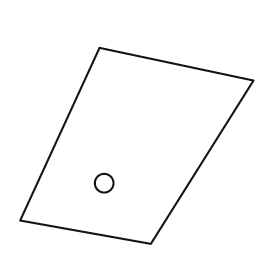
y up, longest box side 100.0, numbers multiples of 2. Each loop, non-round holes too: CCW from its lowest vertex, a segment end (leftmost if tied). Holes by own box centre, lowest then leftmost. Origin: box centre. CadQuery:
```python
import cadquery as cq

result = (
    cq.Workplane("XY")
    .moveTo(6.0, -42.0)
    .lineTo(50.0, 28.0)
    .lineTo(-16.0, 42.0)
    .lineTo(-50.0, -32.0)
    .close()
    .moveTo(-14.0, -16.0)
    .circle(4.0)
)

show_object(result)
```